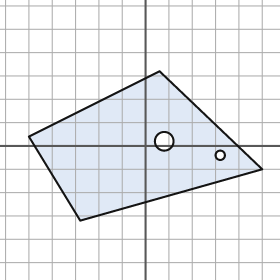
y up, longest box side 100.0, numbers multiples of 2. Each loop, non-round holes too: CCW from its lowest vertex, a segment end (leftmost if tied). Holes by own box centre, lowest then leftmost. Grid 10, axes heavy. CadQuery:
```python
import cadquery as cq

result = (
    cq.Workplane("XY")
    .moveTo(-28.0, -32.0)
    .lineTo(50.0, -10.0)
    .lineTo(6.0, 32.0)
    .lineTo(-50.0, 4.0)
    .close()
    .moveTo(32.0, -4.0)
    .circle(2.0)
    .moveTo(8.0, 2.0)
    .circle(4.0)
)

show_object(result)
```